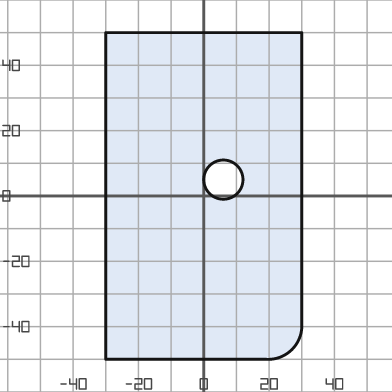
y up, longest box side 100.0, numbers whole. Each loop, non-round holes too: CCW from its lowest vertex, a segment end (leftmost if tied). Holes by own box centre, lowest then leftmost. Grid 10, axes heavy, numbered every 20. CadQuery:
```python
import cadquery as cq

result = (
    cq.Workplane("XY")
    .moveTo(-30.0, -50.0)
    .lineTo(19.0, -50.0)
    .threePointArc((27.0, -47.0), (30.0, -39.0))
    .lineTo(30.0, 50.0)
    .lineTo(-30.0, 50.0)
    .close()
    .moveTo(6.0, 5.0)
    .circle(6.0)
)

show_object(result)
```